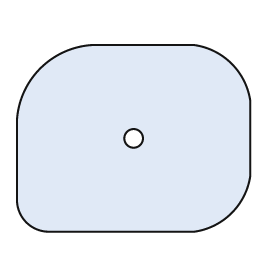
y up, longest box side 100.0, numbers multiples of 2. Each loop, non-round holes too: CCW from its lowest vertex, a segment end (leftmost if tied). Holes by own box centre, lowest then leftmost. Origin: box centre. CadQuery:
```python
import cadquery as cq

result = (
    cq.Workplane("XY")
    .moveTo(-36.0, -40.0)
    .lineTo(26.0, -40.0)
    .threePointArc((42.0, -32.0), (50.0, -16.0))
    .lineTo(50.0, 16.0)
    .threePointArc((42.0, 32.0), (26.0, 40.0))
    .lineTo(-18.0, 40.0)
    .threePointArc((-40.0, 30.0), (-50.0, 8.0))
    .lineTo(-50.0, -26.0)
    .threePointArc((-46.0, -36.0), (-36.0, -40.0))
    .close()
    .moveTo(0.0, 0.0)
    .circle(4.0)
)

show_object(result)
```